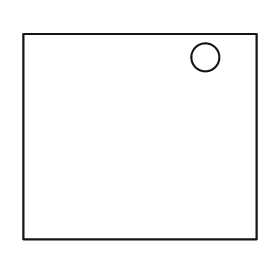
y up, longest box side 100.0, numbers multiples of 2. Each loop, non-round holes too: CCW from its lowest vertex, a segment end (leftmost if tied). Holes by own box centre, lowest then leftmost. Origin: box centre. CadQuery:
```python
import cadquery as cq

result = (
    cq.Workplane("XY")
    .moveTo(-50.0, -44.0)
    .lineTo(50.0, -44.0)
    .lineTo(50.0, 44.0)
    .lineTo(-50.0, 44.0)
    .close()
    .moveTo(28.0, 34.0)
    .circle(6.0)
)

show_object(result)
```